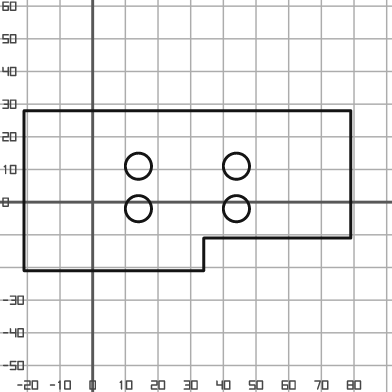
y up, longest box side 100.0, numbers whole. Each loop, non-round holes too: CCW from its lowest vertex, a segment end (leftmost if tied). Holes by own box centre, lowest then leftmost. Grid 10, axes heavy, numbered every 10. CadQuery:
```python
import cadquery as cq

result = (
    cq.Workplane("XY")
    .moveTo(-21.0, -21.0)
    .lineTo(34.0, -21.0)
    .lineTo(34.0, -11.0)
    .lineTo(79.0, -11.0)
    .lineTo(79.0, 28.0)
    .lineTo(-21.0, 28.0)
    .close()
    .moveTo(14.0, -2.0)
    .circle(4.0)
    .moveTo(44.0, -2.0)
    .circle(4.0)
    .moveTo(14.0, 11.0)
    .circle(4.0)
    .moveTo(44.0, 11.0)
    .circle(4.0)
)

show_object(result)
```